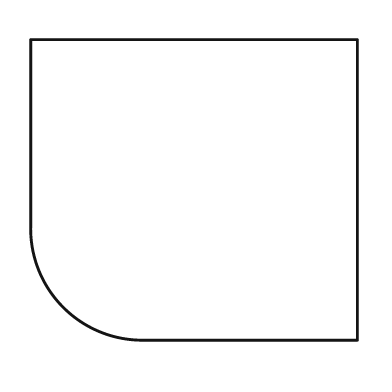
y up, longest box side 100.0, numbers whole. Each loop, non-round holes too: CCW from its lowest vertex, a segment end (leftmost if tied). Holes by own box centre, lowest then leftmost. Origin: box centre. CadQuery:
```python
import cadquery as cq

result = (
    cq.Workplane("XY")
    .moveTo(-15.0, -46.0)
    .lineTo(50.0, -46.0)
    .lineTo(50.0, 46.0)
    .lineTo(-50.0, 46.0)
    .lineTo(-50.0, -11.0)
    .threePointArc((-40.0, -36.0), (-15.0, -46.0))
    .close()
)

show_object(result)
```